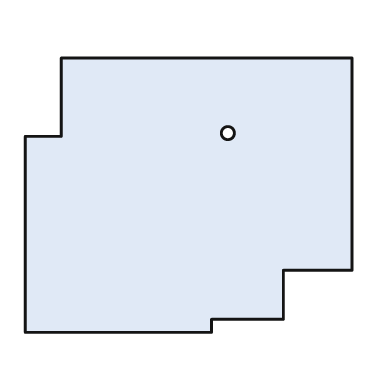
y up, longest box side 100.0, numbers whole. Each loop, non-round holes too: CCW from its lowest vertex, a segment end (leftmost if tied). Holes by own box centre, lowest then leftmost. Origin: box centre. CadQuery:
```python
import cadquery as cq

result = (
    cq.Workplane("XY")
    .moveTo(-50.0, -42.0)
    .lineTo(7.0, -42.0)
    .lineTo(7.0, -38.0)
    .lineTo(29.0, -38.0)
    .lineTo(29.0, -23.0)
    .lineTo(50.0, -23.0)
    .lineTo(50.0, 42.0)
    .lineTo(-39.0, 42.0)
    .lineTo(-39.0, 18.0)
    .lineTo(-50.0, 18.0)
    .close()
    .moveTo(12.0, 19.0)
    .circle(2.0)
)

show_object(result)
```